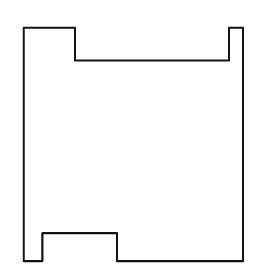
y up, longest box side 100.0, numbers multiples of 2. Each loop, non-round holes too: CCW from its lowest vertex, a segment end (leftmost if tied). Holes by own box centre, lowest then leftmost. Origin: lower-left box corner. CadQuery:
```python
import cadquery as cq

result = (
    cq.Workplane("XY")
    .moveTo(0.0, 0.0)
    .lineTo(8.0, 0.0)
    .lineTo(8.0, 12.0)
    .lineTo(40.0, 12.0)
    .lineTo(40.0, 0.0)
    .lineTo(94.0, 0.0)
    .lineTo(94.0, 100.0)
    .lineTo(88.0, 100.0)
    .lineTo(88.0, 86.0)
    .lineTo(22.0, 86.0)
    .lineTo(22.0, 100.0)
    .lineTo(0.0, 100.0)
    .close()
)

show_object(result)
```